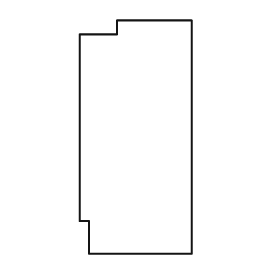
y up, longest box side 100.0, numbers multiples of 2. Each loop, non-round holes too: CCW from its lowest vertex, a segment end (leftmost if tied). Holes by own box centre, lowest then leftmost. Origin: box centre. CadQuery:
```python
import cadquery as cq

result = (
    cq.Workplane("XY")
    .moveTo(-20.0, -50.0)
    .lineTo(24.0, -50.0)
    .lineTo(24.0, 50.0)
    .lineTo(-8.0, 50.0)
    .lineTo(-8.0, 44.0)
    .lineTo(-24.0, 44.0)
    .lineTo(-24.0, -36.0)
    .lineTo(-20.0, -36.0)
    .close()
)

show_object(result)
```